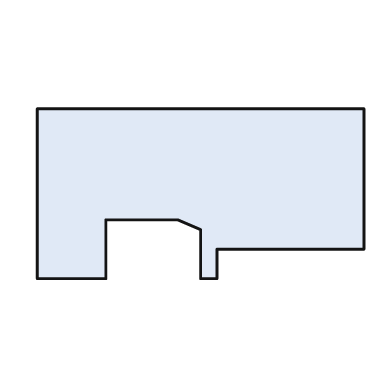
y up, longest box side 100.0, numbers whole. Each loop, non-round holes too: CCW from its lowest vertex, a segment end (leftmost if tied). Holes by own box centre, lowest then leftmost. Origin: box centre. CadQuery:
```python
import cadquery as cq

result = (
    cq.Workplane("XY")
    .moveTo(-50.0, -26.0)
    .lineTo(-29.0, -26.0)
    .lineTo(-29.0, -8.0)
    .lineTo(-7.0, -8.0)
    .lineTo(0.0, -11.0)
    .lineTo(0.0, -26.0)
    .lineTo(5.0, -26.0)
    .lineTo(5.0, -17.0)
    .lineTo(50.0, -17.0)
    .lineTo(50.0, 26.0)
    .lineTo(-50.0, 26.0)
    .close()
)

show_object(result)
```